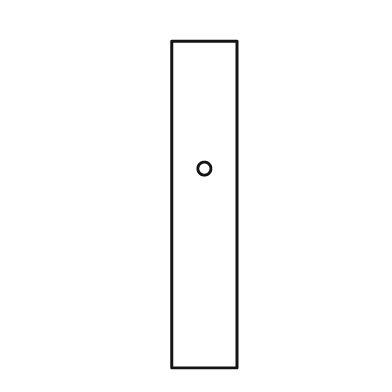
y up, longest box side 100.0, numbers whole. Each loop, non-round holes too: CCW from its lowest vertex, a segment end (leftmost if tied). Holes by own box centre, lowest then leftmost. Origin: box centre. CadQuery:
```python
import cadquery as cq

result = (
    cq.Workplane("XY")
    .moveTo(-10.0, -50.0)
    .lineTo(10.0, -50.0)
    .lineTo(10.0, 50.0)
    .lineTo(-10.0, 50.0)
    .close()
    .moveTo(0.0, 11.0)
    .circle(2.0)
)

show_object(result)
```